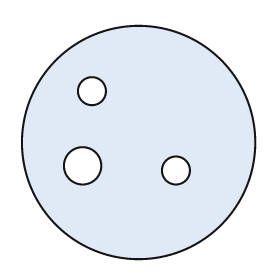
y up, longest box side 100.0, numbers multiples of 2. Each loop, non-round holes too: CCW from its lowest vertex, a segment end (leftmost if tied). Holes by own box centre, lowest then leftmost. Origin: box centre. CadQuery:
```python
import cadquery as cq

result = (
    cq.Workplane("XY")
    .moveTo(0.0, 0.0)
    .circle(50.0)
    .moveTo(16.0, -12.0)
    .circle(6.0)
    .moveTo(-24.0, -10.0)
    .circle(8.0)
    .moveTo(-20.0, 22.0)
    .circle(6.0)
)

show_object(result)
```